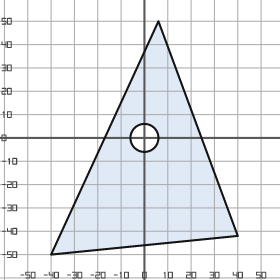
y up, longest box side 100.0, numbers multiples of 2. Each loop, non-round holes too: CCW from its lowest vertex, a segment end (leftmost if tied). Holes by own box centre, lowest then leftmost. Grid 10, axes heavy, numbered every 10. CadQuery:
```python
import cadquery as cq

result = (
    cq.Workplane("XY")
    .moveTo(-40.0, -50.0)
    .lineTo(40.0, -42.0)
    .lineTo(6.0, 50.0)
    .close()
    .moveTo(0.0, 0.0)
    .circle(6.0)
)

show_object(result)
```